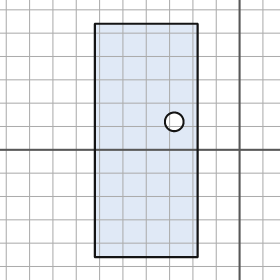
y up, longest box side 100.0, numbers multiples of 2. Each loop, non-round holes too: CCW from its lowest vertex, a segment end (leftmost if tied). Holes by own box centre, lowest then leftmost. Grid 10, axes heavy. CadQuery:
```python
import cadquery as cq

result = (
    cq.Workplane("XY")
    .moveTo(-62.0, -46.0)
    .lineTo(-18.0, -46.0)
    .lineTo(-18.0, 54.0)
    .lineTo(-62.0, 54.0)
    .close()
    .moveTo(-28.0, 12.0)
    .circle(4.0)
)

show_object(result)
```